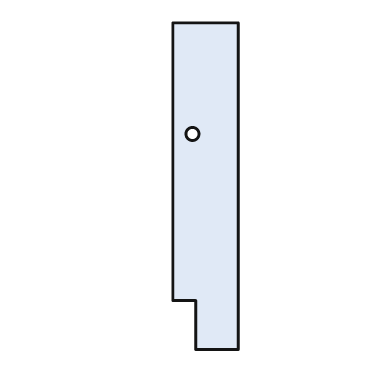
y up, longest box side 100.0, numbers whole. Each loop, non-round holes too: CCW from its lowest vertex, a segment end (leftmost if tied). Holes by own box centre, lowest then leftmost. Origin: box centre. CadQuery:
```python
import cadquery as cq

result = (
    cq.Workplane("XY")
    .moveTo(-3.0, -50.0)
    .lineTo(10.0, -50.0)
    .lineTo(10.0, 50.0)
    .lineTo(-10.0, 50.0)
    .lineTo(-10.0, -35.0)
    .lineTo(-3.0, -35.0)
    .close()
    .moveTo(-4.0, 16.0)
    .circle(2.0)
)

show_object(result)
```